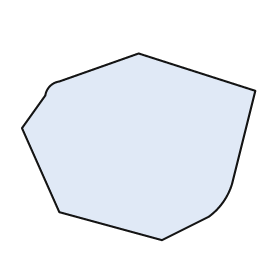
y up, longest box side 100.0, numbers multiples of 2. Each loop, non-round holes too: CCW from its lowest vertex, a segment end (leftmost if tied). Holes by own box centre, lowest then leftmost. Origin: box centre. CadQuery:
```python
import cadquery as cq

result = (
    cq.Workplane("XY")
    .moveTo(10.0, -40.0)
    .lineTo(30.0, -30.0)
    .threePointArc((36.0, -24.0), (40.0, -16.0))
    .lineTo(50.0, 24.0)
    .lineTo(0.0, 40.0)
    .lineTo(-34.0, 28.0)
    .threePointArc((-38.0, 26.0), (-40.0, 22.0))
    .lineTo(-50.0, 8.0)
    .lineTo(-34.0, -28.0)
    .close()
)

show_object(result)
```